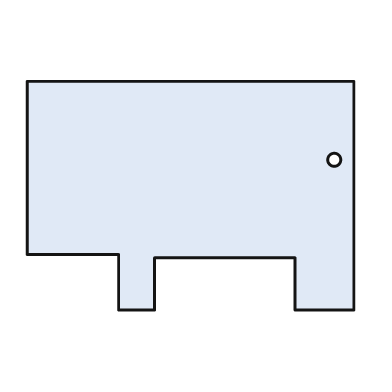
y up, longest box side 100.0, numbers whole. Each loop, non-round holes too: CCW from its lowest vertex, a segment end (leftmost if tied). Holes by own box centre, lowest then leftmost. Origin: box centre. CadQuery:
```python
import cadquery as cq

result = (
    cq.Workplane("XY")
    .moveTo(-22.0, -35.0)
    .lineTo(-11.0, -35.0)
    .lineTo(-11.0, -19.0)
    .lineTo(32.0, -19.0)
    .lineTo(32.0, -35.0)
    .lineTo(50.0, -35.0)
    .lineTo(50.0, 35.0)
    .lineTo(-50.0, 35.0)
    .lineTo(-50.0, -18.0)
    .lineTo(-22.0, -18.0)
    .close()
    .moveTo(44.0, 11.0)
    .circle(2.0)
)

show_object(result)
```